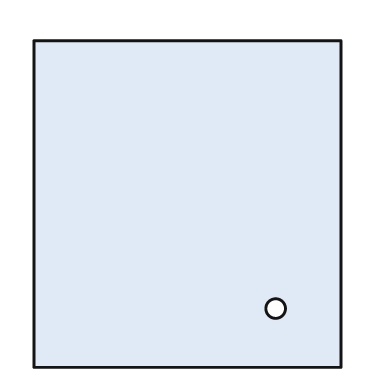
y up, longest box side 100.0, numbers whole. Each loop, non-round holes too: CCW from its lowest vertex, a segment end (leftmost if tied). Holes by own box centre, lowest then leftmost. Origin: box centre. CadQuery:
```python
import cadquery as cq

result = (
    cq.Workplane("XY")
    .moveTo(-47.0, -50.0)
    .lineTo(47.0, -50.0)
    .lineTo(47.0, 50.0)
    .lineTo(-47.0, 50.0)
    .close()
    .moveTo(27.0, -32.0)
    .circle(3.0)
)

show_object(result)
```